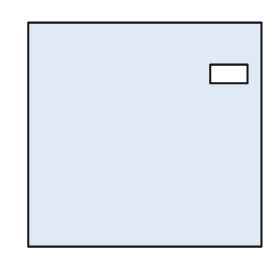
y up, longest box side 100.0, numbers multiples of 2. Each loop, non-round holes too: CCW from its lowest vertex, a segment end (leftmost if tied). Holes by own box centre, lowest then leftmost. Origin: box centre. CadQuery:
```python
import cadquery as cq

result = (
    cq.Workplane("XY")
    .moveTo(-50.0, -48.0)
    .lineTo(50.0, -48.0)
    .lineTo(50.0, 48.0)
    .lineTo(-50.0, 48.0)
    .close()
    .moveTo(28.0, 22.0)
    .lineTo(44.0, 22.0)
    .lineTo(44.0, 30.0)
    .lineTo(28.0, 30.0)
    .close()
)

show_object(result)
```